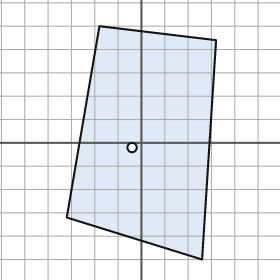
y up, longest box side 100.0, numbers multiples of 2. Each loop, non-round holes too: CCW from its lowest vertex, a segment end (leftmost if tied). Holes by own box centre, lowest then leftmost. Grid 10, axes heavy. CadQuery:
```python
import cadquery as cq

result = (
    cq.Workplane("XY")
    .moveTo(26.0, -50.0)
    .lineTo(32.0, 44.0)
    .lineTo(-18.0, 50.0)
    .lineTo(-32.0, -32.0)
    .close()
    .moveTo(-4.0, -2.0)
    .circle(2.0)
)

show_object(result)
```